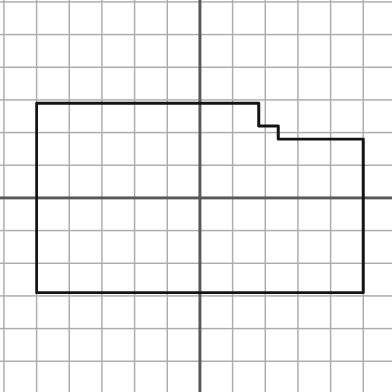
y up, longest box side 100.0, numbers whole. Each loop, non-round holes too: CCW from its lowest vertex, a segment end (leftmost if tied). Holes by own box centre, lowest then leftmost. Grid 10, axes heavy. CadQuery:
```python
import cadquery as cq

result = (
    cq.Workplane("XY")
    .moveTo(-50.0, -29.0)
    .lineTo(50.0, -29.0)
    .lineTo(50.0, 18.0)
    .lineTo(24.0, 18.0)
    .lineTo(24.0, 22.0)
    .lineTo(18.0, 22.0)
    .lineTo(18.0, 29.0)
    .lineTo(-50.0, 29.0)
    .close()
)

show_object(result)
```